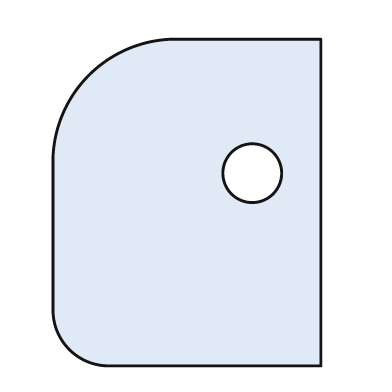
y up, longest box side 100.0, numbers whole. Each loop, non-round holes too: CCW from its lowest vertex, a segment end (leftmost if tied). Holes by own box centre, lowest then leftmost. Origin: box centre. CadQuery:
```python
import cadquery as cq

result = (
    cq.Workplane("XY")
    .moveTo(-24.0, -50.0)
    .lineTo(41.0, -50.0)
    .lineTo(41.0, 50.0)
    .lineTo(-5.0, 50.0)
    .threePointArc((-30.0, 39.0), (-41.0, 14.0))
    .lineTo(-41.0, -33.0)
    .threePointArc((-36.0, -45.0), (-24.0, -50.0))
    .close()
    .moveTo(20.0, 9.0)
    .circle(9.0)
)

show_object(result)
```